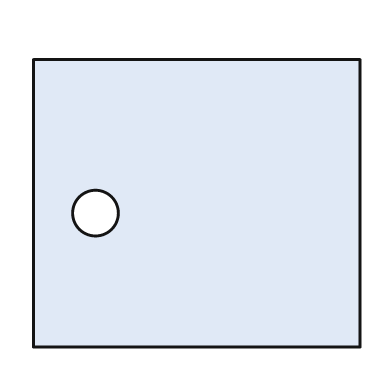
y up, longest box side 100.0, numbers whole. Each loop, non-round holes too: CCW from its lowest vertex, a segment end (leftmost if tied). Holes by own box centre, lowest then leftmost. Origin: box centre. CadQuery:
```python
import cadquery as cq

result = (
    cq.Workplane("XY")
    .moveTo(-50.0, -44.0)
    .lineTo(50.0, -44.0)
    .lineTo(50.0, 44.0)
    .lineTo(-50.0, 44.0)
    .close()
    .moveTo(-31.0, -3.0)
    .circle(7.0)
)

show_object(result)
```